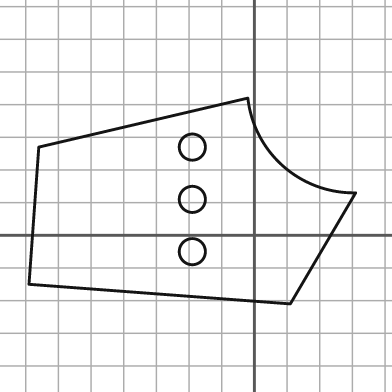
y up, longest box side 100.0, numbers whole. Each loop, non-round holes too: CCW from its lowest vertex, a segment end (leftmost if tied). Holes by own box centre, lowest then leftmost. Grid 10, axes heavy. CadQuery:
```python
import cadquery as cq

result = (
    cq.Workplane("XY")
    .moveTo(11.0, -21.0)
    .lineTo(31.0, 13.0)
    .threePointArc((9.0, 21.0), (-2.0, 42.0))
    .lineTo(-66.0, 27.0)
    .lineTo(-69.0, -15.0)
    .close()
    .moveTo(-19.0, -5.0)
    .circle(4.0)
    .moveTo(-19.0, 11.0)
    .circle(4.0)
    .moveTo(-19.0, 27.0)
    .circle(4.0)
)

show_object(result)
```